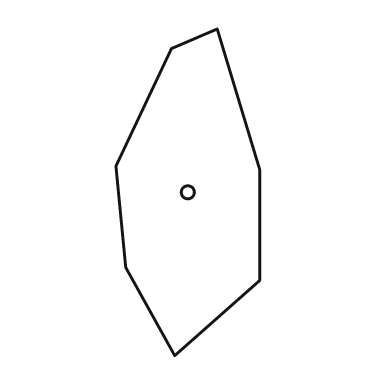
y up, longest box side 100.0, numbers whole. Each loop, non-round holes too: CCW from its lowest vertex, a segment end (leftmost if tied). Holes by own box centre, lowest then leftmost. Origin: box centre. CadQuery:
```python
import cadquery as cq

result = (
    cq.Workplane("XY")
    .moveTo(-4.0, -50.0)
    .lineTo(22.0, -27.0)
    .lineTo(22.0, 7.0)
    .lineTo(9.0, 50.0)
    .lineTo(-5.0, 44.0)
    .lineTo(-22.0, 8.0)
    .lineTo(-19.0, -23.0)
    .close()
    .moveTo(0.0, 0.0)
    .circle(2.0)
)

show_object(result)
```